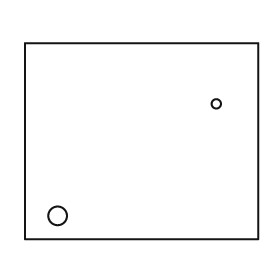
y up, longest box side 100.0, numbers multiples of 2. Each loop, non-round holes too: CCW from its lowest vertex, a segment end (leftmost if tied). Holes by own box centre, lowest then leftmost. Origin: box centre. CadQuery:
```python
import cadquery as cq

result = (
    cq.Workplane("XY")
    .moveTo(-50.0, -42.0)
    .lineTo(50.0, -42.0)
    .lineTo(50.0, 42.0)
    .lineTo(-50.0, 42.0)
    .close()
    .moveTo(-36.0, -32.0)
    .circle(4.0)
    .moveTo(32.0, 16.0)
    .circle(2.0)
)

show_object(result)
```